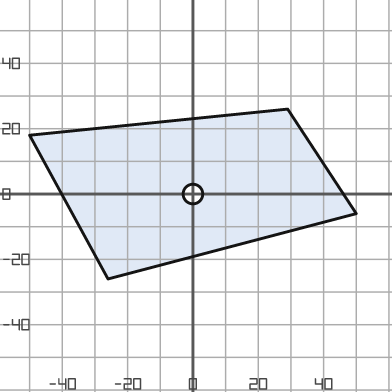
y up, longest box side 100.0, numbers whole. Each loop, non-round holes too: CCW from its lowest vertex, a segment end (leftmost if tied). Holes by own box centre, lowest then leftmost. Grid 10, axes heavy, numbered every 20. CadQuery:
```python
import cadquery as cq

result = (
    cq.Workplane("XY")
    .moveTo(-26.0, -26.0)
    .lineTo(50.0, -6.0)
    .lineTo(29.0, 26.0)
    .lineTo(-50.0, 18.0)
    .close()
    .moveTo(0.0, 0.0)
    .circle(3.0)
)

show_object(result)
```